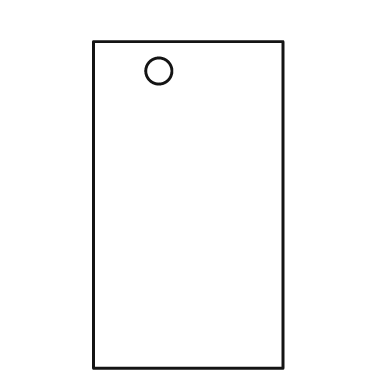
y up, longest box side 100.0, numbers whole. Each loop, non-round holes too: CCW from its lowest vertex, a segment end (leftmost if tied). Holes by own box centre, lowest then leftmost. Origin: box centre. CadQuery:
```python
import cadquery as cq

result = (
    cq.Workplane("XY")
    .moveTo(-29.0, -50.0)
    .lineTo(29.0, -50.0)
    .lineTo(29.0, 50.0)
    .lineTo(-29.0, 50.0)
    .close()
    .moveTo(-9.0, 41.0)
    .circle(4.0)
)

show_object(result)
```